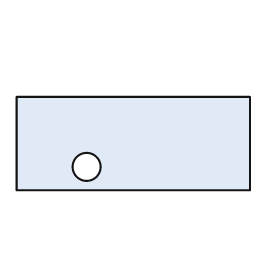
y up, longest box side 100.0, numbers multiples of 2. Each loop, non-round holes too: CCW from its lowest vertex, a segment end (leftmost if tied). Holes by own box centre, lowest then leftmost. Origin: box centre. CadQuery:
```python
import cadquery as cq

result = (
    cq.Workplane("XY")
    .moveTo(-50.0, -20.0)
    .lineTo(50.0, -20.0)
    .lineTo(50.0, 20.0)
    .lineTo(-50.0, 20.0)
    .close()
    .moveTo(-20.0, -10.0)
    .circle(6.0)
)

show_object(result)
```